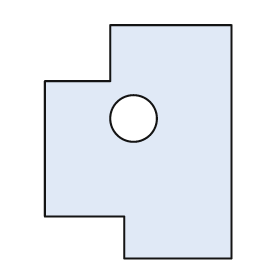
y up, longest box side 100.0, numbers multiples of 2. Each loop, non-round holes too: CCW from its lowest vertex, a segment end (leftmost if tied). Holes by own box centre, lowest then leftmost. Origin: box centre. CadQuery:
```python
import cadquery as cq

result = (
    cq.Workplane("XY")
    .moveTo(-6.0, -50.0)
    .lineTo(40.0, -50.0)
    .lineTo(40.0, 50.0)
    .lineTo(-12.0, 50.0)
    .lineTo(-12.0, 26.0)
    .lineTo(-40.0, 26.0)
    .lineTo(-40.0, -32.0)
    .lineTo(-6.0, -32.0)
    .close()
    .moveTo(-2.0, 10.0)
    .circle(10.0)
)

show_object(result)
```